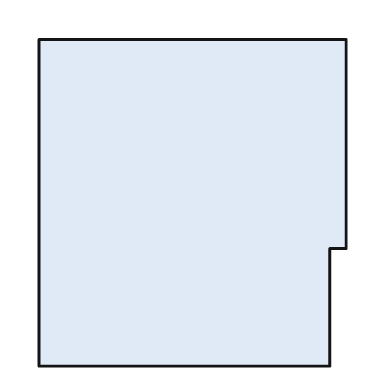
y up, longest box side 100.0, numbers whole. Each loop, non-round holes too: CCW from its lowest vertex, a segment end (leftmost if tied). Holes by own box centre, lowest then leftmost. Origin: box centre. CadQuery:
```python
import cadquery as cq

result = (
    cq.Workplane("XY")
    .moveTo(-47.0, -50.0)
    .lineTo(42.0, -50.0)
    .lineTo(42.0, -14.0)
    .lineTo(47.0, -14.0)
    .lineTo(47.0, 50.0)
    .lineTo(-47.0, 50.0)
    .close()
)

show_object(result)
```